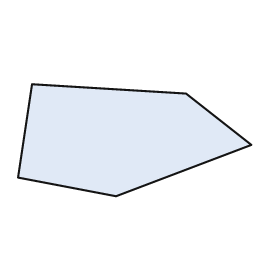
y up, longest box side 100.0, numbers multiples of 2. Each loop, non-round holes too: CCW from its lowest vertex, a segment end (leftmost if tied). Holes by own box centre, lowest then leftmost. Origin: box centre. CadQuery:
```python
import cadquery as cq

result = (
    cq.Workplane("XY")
    .moveTo(-8.0, -24.0)
    .lineTo(50.0, -2.0)
    .lineTo(22.0, 20.0)
    .lineTo(-44.0, 24.0)
    .lineTo(-50.0, -16.0)
    .close()
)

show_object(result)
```